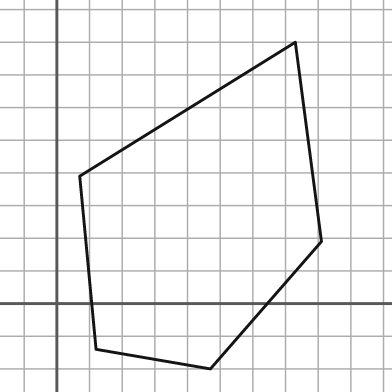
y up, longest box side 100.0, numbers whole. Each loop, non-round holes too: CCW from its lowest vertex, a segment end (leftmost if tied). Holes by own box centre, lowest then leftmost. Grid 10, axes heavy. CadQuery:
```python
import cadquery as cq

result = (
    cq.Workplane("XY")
    .moveTo(47.0, -20.0)
    .lineTo(81.0, 19.0)
    .lineTo(73.0, 80.0)
    .lineTo(7.0, 39.0)
    .lineTo(12.0, -14.0)
    .close()
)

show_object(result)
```